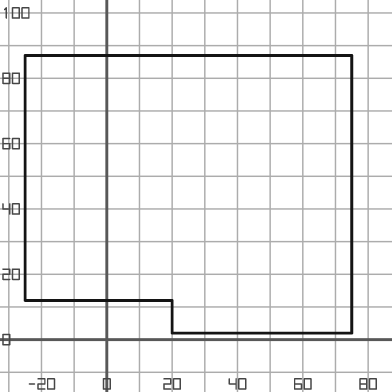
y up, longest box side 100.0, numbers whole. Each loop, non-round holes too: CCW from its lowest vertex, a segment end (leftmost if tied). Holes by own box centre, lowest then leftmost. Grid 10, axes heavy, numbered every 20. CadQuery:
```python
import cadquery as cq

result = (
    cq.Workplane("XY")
    .moveTo(20.0, 2.0)
    .lineTo(75.0, 2.0)
    .lineTo(75.0, 87.0)
    .lineTo(-25.0, 87.0)
    .lineTo(-25.0, 12.0)
    .lineTo(20.0, 12.0)
    .close()
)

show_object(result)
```